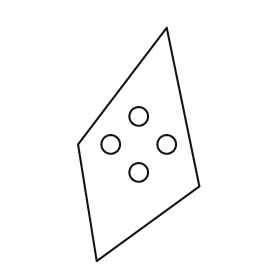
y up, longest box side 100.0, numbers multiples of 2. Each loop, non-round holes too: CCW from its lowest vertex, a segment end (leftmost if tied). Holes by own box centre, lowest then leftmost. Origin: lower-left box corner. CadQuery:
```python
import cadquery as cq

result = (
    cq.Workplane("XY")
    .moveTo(8.0, 0.0)
    .lineTo(52.0, 32.0)
    .lineTo(38.0, 100.0)
    .lineTo(0.0, 50.0)
    .close()
    .moveTo(26.0, 38.0)
    .circle(4.0)
    .moveTo(14.0, 50.0)
    .circle(4.0)
    .moveTo(38.0, 50.0)
    .circle(4.0)
    .moveTo(26.0, 62.0)
    .circle(4.0)
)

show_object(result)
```